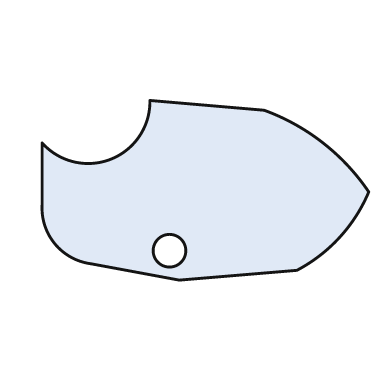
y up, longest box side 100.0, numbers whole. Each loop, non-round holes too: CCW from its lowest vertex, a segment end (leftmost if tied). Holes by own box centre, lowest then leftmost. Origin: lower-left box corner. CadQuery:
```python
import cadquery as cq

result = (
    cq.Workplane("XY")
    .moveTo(42.0, 0.0)
    .lineTo(78.0, 3.0)
    .threePointArc((91.0, 13.0), (100.0, 27.0))
    .threePointArc((86.0, 42.0), (68.0, 52.0))
    .lineTo(33.0, 55.0)
    .threePointArc((21.0, 37.0), (0.0, 42.0))
    .lineTo(0.0, 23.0)
    .threePointArc((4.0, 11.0), (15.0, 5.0))
    .close()
    .moveTo(39.0, 9.0)
    .circle(5.0)
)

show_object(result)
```